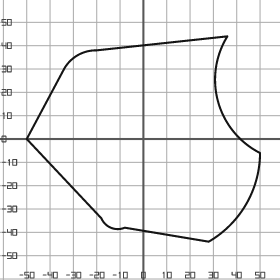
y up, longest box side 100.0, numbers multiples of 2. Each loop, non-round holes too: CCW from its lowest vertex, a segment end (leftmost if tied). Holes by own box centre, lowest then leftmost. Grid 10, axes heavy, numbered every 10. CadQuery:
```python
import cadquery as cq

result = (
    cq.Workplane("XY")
    .moveTo(28.0, -44.0)
    .threePointArc((44.0, -28.0), (50.0, -6.0))
    .threePointArc((32.0, 16.0), (36.0, 44.0))
    .lineTo(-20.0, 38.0)
    .threePointArc((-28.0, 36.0), (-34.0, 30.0))
    .lineTo(-50.0, 0.0)
    .lineTo(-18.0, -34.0)
    .threePointArc((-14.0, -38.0), (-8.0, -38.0))
    .close()
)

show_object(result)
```